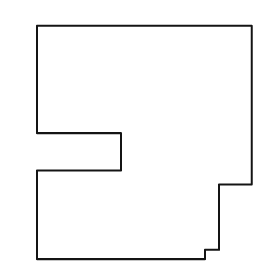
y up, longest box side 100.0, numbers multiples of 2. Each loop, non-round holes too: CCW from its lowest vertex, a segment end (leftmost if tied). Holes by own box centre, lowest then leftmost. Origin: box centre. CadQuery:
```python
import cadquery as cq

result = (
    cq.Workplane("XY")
    .moveTo(-46.0, -50.0)
    .lineTo(26.0, -50.0)
    .lineTo(26.0, -46.0)
    .lineTo(32.0, -46.0)
    .lineTo(32.0, -18.0)
    .lineTo(46.0, -18.0)
    .lineTo(46.0, 50.0)
    .lineTo(-46.0, 50.0)
    .lineTo(-46.0, 4.0)
    .lineTo(-10.0, 4.0)
    .lineTo(-10.0, -12.0)
    .lineTo(-46.0, -12.0)
    .close()
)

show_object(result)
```